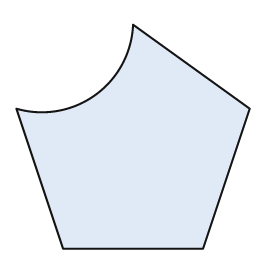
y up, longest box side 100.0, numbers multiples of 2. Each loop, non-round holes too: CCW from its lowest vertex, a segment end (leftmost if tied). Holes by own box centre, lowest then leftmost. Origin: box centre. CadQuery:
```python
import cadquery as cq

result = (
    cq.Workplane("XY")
    .moveTo(-30.0, -48.0)
    .lineTo(30.0, -48.0)
    .lineTo(50.0, 12.0)
    .lineTo(0.0, 48.0)
    .threePointArc((-16.0, 18.0), (-50.0, 12.0))
    .close()
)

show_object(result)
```